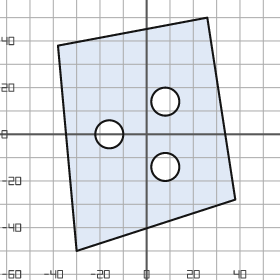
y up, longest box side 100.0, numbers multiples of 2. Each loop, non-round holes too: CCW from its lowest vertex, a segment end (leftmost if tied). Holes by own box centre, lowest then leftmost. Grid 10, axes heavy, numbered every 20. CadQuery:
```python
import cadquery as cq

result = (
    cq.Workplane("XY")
    .moveTo(-30.0, -50.0)
    .lineTo(38.0, -28.0)
    .lineTo(26.0, 50.0)
    .lineTo(-38.0, 38.0)
    .close()
    .moveTo(8.0, -14.0)
    .circle(6.0)
    .moveTo(-16.0, 0.0)
    .circle(6.0)
    .moveTo(8.0, 14.0)
    .circle(6.0)
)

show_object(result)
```